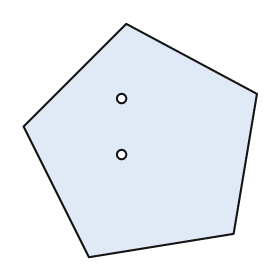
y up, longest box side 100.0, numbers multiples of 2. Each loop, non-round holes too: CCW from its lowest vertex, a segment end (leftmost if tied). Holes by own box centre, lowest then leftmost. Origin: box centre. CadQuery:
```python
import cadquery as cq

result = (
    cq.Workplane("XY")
    .moveTo(-22.0, -50.0)
    .lineTo(40.0, -40.0)
    .lineTo(50.0, 20.0)
    .lineTo(-6.0, 50.0)
    .lineTo(-50.0, 6.0)
    .close()
    .moveTo(-8.0, -6.0)
    .circle(2.0)
    .moveTo(-8.0, 18.0)
    .circle(2.0)
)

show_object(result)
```